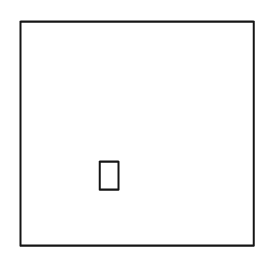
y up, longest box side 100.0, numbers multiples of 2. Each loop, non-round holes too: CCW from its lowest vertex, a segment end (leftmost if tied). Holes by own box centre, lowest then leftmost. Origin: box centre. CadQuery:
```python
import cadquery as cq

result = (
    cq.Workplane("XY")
    .moveTo(-50.0, -48.0)
    .lineTo(50.0, -48.0)
    .lineTo(50.0, 48.0)
    .lineTo(-50.0, 48.0)
    .close()
    .moveTo(-16.0, -24.0)
    .lineTo(-8.0, -24.0)
    .lineTo(-8.0, -12.0)
    .lineTo(-16.0, -12.0)
    .close()
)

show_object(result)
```